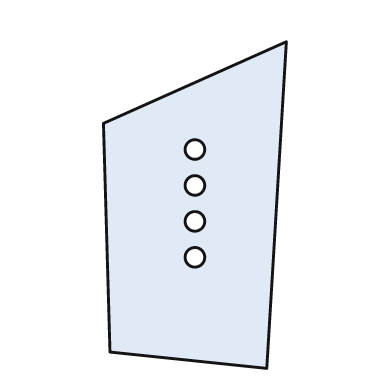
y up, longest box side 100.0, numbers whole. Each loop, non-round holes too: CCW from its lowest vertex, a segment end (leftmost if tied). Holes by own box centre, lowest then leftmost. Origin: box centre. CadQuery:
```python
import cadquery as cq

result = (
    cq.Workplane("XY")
    .moveTo(22.0, -50.0)
    .lineTo(28.0, 50.0)
    .lineTo(-28.0, 25.0)
    .lineTo(-26.0, -45.0)
    .close()
    .moveTo(0.0, -16.0)
    .circle(3.0)
    .moveTo(0.0, -5.0)
    .circle(3.0)
    .moveTo(0.0, 6.0)
    .circle(3.0)
    .moveTo(0.0, 17.0)
    .circle(3.0)
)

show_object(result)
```